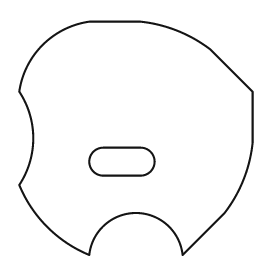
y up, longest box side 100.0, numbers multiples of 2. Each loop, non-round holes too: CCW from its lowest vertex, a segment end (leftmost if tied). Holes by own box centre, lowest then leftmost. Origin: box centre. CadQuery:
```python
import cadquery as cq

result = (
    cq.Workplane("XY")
    .moveTo(-20.0, -50.0)
    .threePointArc((0.0, -32.0), (20.0, -50.0))
    .lineTo(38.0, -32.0)
    .threePointArc((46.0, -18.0), (50.0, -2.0))
    .lineTo(50.0, 20.0)
    .lineTo(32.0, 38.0)
    .threePointArc((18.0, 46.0), (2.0, 50.0))
    .lineTo(-20.0, 50.0)
    .threePointArc((-40.0, 40.0), (-50.0, 20.0))
    .threePointArc((-44.0, 0.0), (-50.0, -20.0))
    .threePointArc((-38.0, -38.0), (-20.0, -50.0))
    .close()
    .moveTo(-14.0, -16.0)
    .lineTo(2.0, -16.0)
    .threePointArc((8.0, -10.0), (2.0, -4.0))
    .lineTo(-14.0, -4.0)
    .threePointArc((-20.0, -10.0), (-14.0, -16.0))
    .close()
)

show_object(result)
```